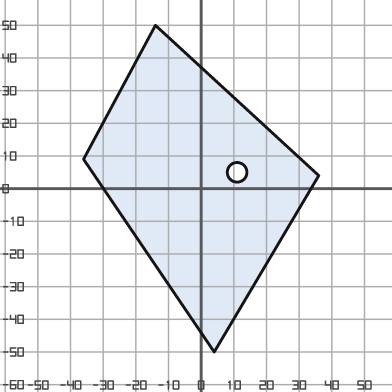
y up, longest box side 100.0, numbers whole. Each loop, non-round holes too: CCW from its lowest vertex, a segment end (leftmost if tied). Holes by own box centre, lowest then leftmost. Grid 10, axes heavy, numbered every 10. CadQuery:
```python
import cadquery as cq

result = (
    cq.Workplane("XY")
    .moveTo(4.0, -50.0)
    .lineTo(36.0, 4.0)
    .lineTo(-14.0, 50.0)
    .lineTo(-36.0, 9.0)
    .close()
    .moveTo(11.0, 5.0)
    .circle(3.0)
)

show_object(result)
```